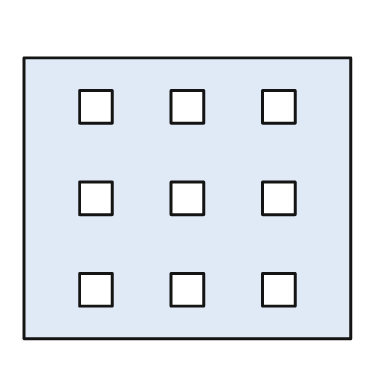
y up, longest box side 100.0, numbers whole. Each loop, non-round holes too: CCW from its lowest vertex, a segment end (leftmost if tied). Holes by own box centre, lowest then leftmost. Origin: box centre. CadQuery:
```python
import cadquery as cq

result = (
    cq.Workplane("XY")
    .moveTo(-50.0, -43.0)
    .lineTo(50.0, -43.0)
    .lineTo(50.0, 43.0)
    .lineTo(-50.0, 43.0)
    .close()
    .moveTo(-33.0, -33.0)
    .lineTo(-23.0, -33.0)
    .lineTo(-23.0, -23.0)
    .lineTo(-33.0, -23.0)
    .close()
    .moveTo(-5.0, -33.0)
    .lineTo(5.0, -33.0)
    .lineTo(5.0, -23.0)
    .lineTo(-5.0, -23.0)
    .close()
    .moveTo(23.0, -33.0)
    .lineTo(33.0, -33.0)
    .lineTo(33.0, -23.0)
    .lineTo(23.0, -23.0)
    .close()
    .moveTo(-33.0, -5.0)
    .lineTo(-23.0, -5.0)
    .lineTo(-23.0, 5.0)
    .lineTo(-33.0, 5.0)
    .close()
    .moveTo(-5.0, -5.0)
    .lineTo(5.0, -5.0)
    .lineTo(5.0, 5.0)
    .lineTo(-5.0, 5.0)
    .close()
    .moveTo(23.0, -5.0)
    .lineTo(33.0, -5.0)
    .lineTo(33.0, 5.0)
    .lineTo(23.0, 5.0)
    .close()
    .moveTo(-33.0, 23.0)
    .lineTo(-23.0, 23.0)
    .lineTo(-23.0, 33.0)
    .lineTo(-33.0, 33.0)
    .close()
    .moveTo(-5.0, 23.0)
    .lineTo(5.0, 23.0)
    .lineTo(5.0, 33.0)
    .lineTo(-5.0, 33.0)
    .close()
    .moveTo(23.0, 23.0)
    .lineTo(33.0, 23.0)
    .lineTo(33.0, 33.0)
    .lineTo(23.0, 33.0)
    .close()
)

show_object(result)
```